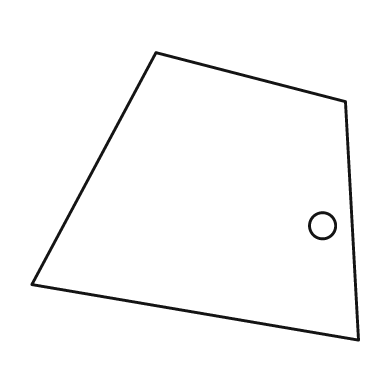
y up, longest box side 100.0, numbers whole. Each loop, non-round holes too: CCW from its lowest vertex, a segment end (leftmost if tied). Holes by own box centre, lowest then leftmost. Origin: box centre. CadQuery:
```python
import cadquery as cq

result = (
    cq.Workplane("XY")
    .moveTo(50.0, -44.0)
    .lineTo(46.0, 29.0)
    .lineTo(-12.0, 44.0)
    .lineTo(-50.0, -27.0)
    .close()
    .moveTo(39.0, -9.0)
    .circle(4.0)
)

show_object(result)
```